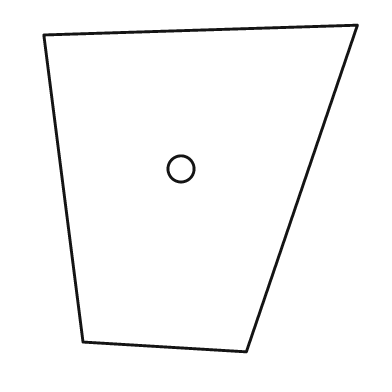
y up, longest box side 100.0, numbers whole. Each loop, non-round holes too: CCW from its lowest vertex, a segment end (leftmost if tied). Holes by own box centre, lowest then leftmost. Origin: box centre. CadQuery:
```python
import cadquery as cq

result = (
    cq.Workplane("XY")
    .moveTo(14.0, -50.0)
    .lineTo(48.0, 50.0)
    .lineTo(-48.0, 47.0)
    .lineTo(-36.0, -47.0)
    .close()
    .moveTo(-6.0, 6.0)
    .circle(4.0)
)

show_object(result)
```